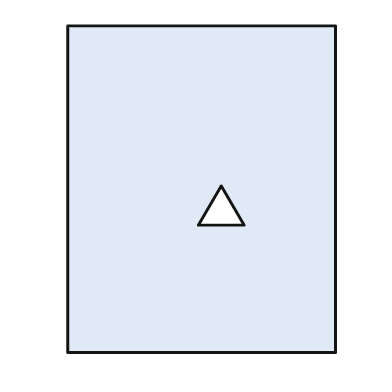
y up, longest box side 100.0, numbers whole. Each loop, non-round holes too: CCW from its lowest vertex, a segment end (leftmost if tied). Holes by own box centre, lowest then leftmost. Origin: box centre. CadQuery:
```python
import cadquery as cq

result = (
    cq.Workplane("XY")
    .moveTo(-41.0, -50.0)
    .lineTo(41.0, -50.0)
    .lineTo(41.0, 50.0)
    .lineTo(-41.0, 50.0)
    .close()
    .moveTo(-1.0, -11.0)
    .lineTo(13.0, -11.0)
    .lineTo(6.0, 1.0)
    .close()
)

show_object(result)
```